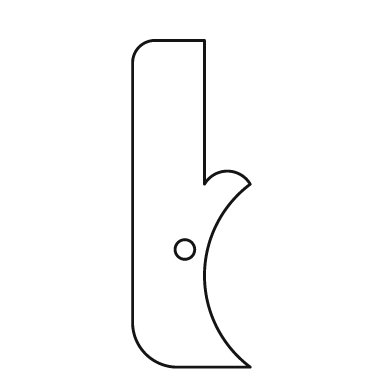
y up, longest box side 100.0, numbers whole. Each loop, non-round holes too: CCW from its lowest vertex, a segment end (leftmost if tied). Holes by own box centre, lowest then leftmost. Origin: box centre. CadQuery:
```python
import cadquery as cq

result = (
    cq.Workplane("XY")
    .moveTo(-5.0, -50.0)
    .lineTo(18.0, -50.0)
    .threePointArc((4.0, -22.0), (18.0, 6.0))
    .threePointArc((11.0, 10.0), (4.0, 6.0))
    .lineTo(4.0, 50.0)
    .lineTo(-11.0, 50.0)
    .threePointArc((-16.0, 48.0), (-18.0, 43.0))
    .lineTo(-18.0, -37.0)
    .threePointArc((-14.0, -46.0), (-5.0, -50.0))
    .close()
    .moveTo(-2.0, -14.0)
    .circle(3.0)
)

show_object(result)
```